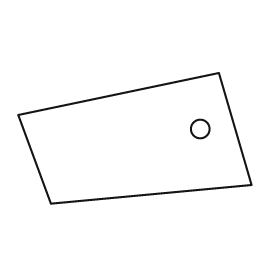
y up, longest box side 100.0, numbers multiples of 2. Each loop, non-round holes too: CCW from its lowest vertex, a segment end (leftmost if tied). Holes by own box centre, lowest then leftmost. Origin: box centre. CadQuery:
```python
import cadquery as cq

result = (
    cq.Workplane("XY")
    .moveTo(-36.0, -28.0)
    .lineTo(50.0, -20.0)
    .lineTo(36.0, 28.0)
    .lineTo(-50.0, 10.0)
    .close()
    .moveTo(28.0, 4.0)
    .circle(4.0)
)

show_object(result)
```